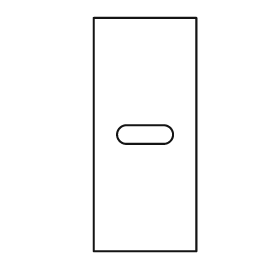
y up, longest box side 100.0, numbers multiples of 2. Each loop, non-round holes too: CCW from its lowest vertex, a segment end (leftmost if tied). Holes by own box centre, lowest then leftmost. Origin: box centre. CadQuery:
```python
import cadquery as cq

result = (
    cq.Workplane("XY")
    .moveTo(-22.0, -50.0)
    .lineTo(22.0, -50.0)
    .lineTo(22.0, 50.0)
    .lineTo(-22.0, 50.0)
    .close()
    .moveTo(-8.0, -4.0)
    .lineTo(8.0, -4.0)
    .threePointArc((12.0, 0.0), (8.0, 4.0))
    .lineTo(-8.0, 4.0)
    .threePointArc((-12.0, 0.0), (-8.0, -4.0))
    .close()
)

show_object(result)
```